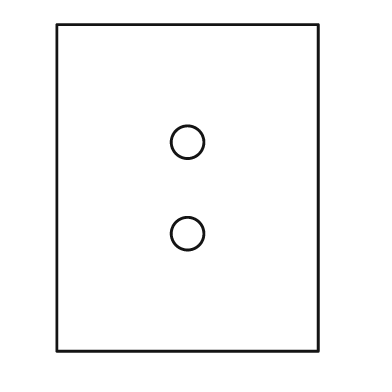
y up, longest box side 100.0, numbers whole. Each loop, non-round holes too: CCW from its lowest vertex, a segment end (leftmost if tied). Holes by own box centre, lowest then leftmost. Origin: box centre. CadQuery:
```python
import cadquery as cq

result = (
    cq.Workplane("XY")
    .moveTo(-40.0, -50.0)
    .lineTo(40.0, -50.0)
    .lineTo(40.0, 50.0)
    .lineTo(-40.0, 50.0)
    .close()
    .moveTo(0.0, -14.0)
    .circle(5.0)
    .moveTo(0.0, 14.0)
    .circle(5.0)
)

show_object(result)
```